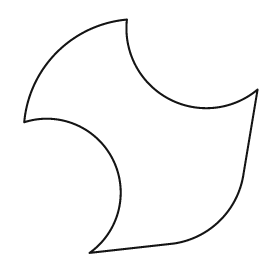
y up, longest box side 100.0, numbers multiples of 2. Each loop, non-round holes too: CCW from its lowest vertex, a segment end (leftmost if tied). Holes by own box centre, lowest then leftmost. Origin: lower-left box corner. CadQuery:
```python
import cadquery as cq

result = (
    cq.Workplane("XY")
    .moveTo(28.0, 0.0)
    .lineTo(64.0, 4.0)
    .threePointArc((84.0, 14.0), (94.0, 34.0))
    .lineTo(100.0, 70.0)
    .threePointArc((62.0, 66.0), (44.0, 100.0))
    .threePointArc((14.0, 86.0), (0.0, 56.0))
    .threePointArc((38.0, 40.0), (28.0, 0.0))
    .close()
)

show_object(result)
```